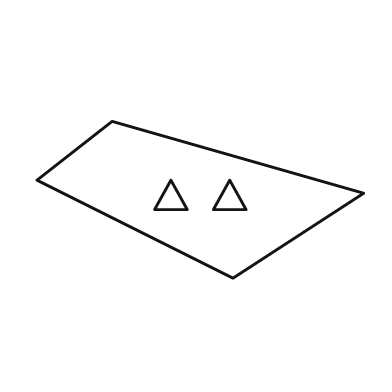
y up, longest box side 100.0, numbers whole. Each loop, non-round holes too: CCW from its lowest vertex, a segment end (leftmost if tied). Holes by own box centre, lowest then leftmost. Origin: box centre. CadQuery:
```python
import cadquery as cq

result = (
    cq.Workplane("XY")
    .moveTo(10.0, -24.0)
    .lineTo(50.0, 2.0)
    .lineTo(-27.0, 24.0)
    .lineTo(-50.0, 6.0)
    .close()
    .moveTo(-14.0, -3.0)
    .lineTo(-4.0, -3.0)
    .lineTo(-9.0, 6.0)
    .close()
    .moveTo(4.0, -3.0)
    .lineTo(14.0, -3.0)
    .lineTo(9.0, 6.0)
    .close()
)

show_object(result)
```